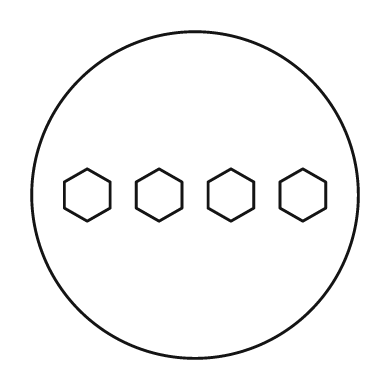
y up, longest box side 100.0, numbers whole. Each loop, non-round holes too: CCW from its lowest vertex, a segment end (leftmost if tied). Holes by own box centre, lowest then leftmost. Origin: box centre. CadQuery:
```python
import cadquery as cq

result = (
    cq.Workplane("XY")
    .moveTo(0.0, 0.0)
    .circle(50.0)
    .moveTo(-33.0, -8.0)
    .lineTo(-26.0, -4.0)
    .lineTo(-26.0, 4.0)
    .lineTo(-33.0, 8.0)
    .lineTo(-40.0, 4.0)
    .lineTo(-40.0, -4.0)
    .close()
    .moveTo(-11.0, -8.0)
    .lineTo(-4.0, -4.0)
    .lineTo(-4.0, 4.0)
    .lineTo(-11.0, 8.0)
    .lineTo(-18.0, 4.0)
    .lineTo(-18.0, -4.0)
    .close()
    .moveTo(11.0, -8.0)
    .lineTo(18.0, -4.0)
    .lineTo(18.0, 4.0)
    .lineTo(11.0, 8.0)
    .lineTo(4.0, 4.0)
    .lineTo(4.0, -4.0)
    .close()
    .moveTo(33.0, -8.0)
    .lineTo(40.0, -4.0)
    .lineTo(40.0, 4.0)
    .lineTo(33.0, 8.0)
    .lineTo(26.0, 4.0)
    .lineTo(26.0, -4.0)
    .close()
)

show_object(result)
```